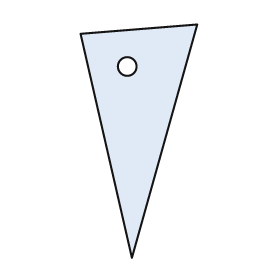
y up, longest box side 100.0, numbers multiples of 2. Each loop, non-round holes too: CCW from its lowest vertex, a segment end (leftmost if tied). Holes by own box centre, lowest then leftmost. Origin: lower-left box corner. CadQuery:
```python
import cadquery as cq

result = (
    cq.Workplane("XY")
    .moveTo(22.0, 0.0)
    .lineTo(50.0, 100.0)
    .lineTo(0.0, 96.0)
    .close()
    .moveTo(20.0, 82.0)
    .circle(4.0)
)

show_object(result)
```